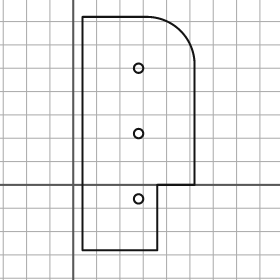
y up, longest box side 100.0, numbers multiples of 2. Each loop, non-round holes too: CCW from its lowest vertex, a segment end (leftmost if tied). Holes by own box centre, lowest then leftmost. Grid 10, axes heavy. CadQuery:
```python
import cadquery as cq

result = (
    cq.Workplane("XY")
    .moveTo(4.0, -28.0)
    .lineTo(36.0, -28.0)
    .lineTo(36.0, 0.0)
    .lineTo(52.0, 0.0)
    .lineTo(52.0, 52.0)
    .threePointArc((46.0, 66.0), (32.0, 72.0))
    .lineTo(4.0, 72.0)
    .close()
    .moveTo(28.0, -6.0)
    .circle(2.0)
    .moveTo(28.0, 22.0)
    .circle(2.0)
    .moveTo(28.0, 50.0)
    .circle(2.0)
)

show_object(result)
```